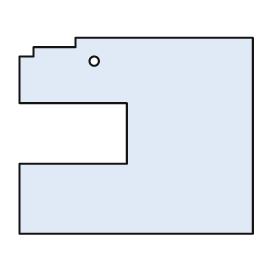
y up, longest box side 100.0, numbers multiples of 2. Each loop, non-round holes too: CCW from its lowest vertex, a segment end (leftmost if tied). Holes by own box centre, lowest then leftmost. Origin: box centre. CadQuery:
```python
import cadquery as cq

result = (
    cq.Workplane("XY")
    .moveTo(-50.0, -42.0)
    .lineTo(50.0, -42.0)
    .lineTo(50.0, 42.0)
    .lineTo(-26.0, 42.0)
    .lineTo(-26.0, 38.0)
    .lineTo(-44.0, 38.0)
    .lineTo(-44.0, 34.0)
    .lineTo(-50.0, 34.0)
    .lineTo(-50.0, 14.0)
    .lineTo(-4.0, 14.0)
    .lineTo(-4.0, -12.0)
    .lineTo(-50.0, -12.0)
    .close()
    .moveTo(-18.0, 32.0)
    .circle(2.0)
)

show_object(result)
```